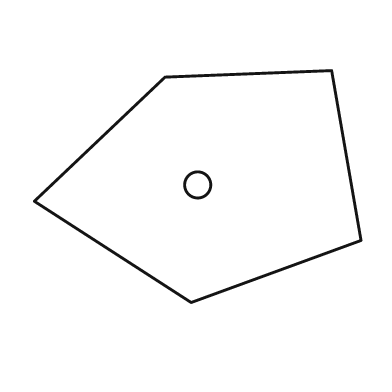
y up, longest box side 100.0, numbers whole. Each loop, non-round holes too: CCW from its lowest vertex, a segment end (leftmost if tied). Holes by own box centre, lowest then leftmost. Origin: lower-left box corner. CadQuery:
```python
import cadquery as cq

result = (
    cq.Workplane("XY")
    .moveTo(48.0, 0.0)
    .lineTo(100.0, 19.0)
    .lineTo(91.0, 71.0)
    .lineTo(40.0, 69.0)
    .lineTo(0.0, 31.0)
    .close()
    .moveTo(50.0, 36.0)
    .circle(4.0)
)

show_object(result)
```